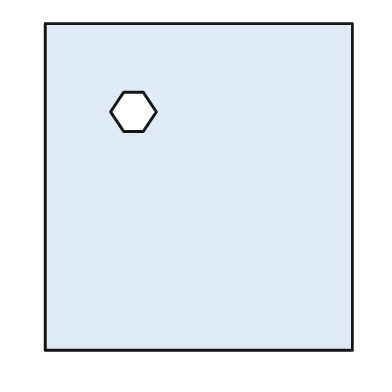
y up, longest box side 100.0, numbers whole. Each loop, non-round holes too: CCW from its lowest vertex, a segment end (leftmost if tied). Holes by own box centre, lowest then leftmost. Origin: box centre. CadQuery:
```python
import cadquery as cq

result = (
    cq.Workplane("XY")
    .moveTo(-47.0, -50.0)
    .lineTo(47.0, -50.0)
    .lineTo(47.0, 50.0)
    .lineTo(-47.0, 50.0)
    .close()
    .moveTo(-23.0, 17.0)
    .lineTo(-17.0, 17.0)
    .lineTo(-13.0, 23.0)
    .lineTo(-17.0, 29.0)
    .lineTo(-23.0, 29.0)
    .lineTo(-27.0, 23.0)
    .close()
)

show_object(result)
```